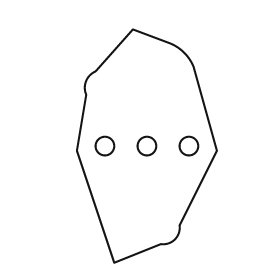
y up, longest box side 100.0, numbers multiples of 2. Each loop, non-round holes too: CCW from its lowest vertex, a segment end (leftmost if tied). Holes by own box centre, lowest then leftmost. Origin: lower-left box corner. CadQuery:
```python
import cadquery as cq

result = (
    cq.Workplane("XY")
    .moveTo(16.0, 0.0)
    .lineTo(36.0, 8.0)
    .threePointArc((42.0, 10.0), (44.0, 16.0))
    .lineTo(60.0, 48.0)
    .lineTo(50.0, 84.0)
    .threePointArc((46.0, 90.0), (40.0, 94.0))
    .lineTo(24.0, 100.0)
    .lineTo(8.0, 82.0)
    .threePointArc((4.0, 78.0), (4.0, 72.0))
    .lineTo(0.0, 48.0)
    .close()
    .moveTo(12.0, 50.0)
    .circle(4.0)
    .moveTo(30.0, 50.0)
    .circle(4.0)
    .moveTo(48.0, 50.0)
    .circle(4.0)
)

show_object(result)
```